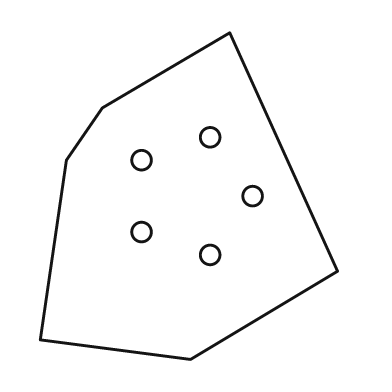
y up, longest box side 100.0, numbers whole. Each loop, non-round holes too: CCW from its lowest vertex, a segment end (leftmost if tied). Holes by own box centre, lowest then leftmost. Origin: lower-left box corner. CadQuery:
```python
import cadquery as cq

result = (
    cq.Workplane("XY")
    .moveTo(46.0, 0.0)
    .lineTo(91.0, 27.0)
    .lineTo(58.0, 100.0)
    .lineTo(19.0, 77.0)
    .lineTo(8.0, 61.0)
    .lineTo(0.0, 6.0)
    .close()
    .moveTo(52.0, 32.0)
    .circle(3.0)
    .moveTo(31.0, 39.0)
    .circle(3.0)
    .moveTo(65.0, 50.0)
    .circle(3.0)
    .moveTo(31.0, 61.0)
    .circle(3.0)
    .moveTo(52.0, 68.0)
    .circle(3.0)
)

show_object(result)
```